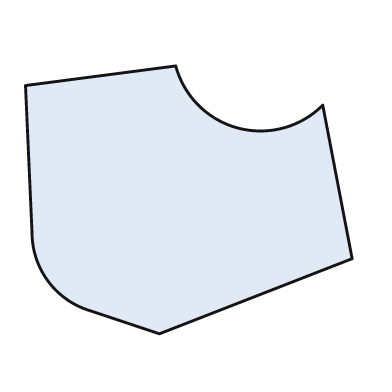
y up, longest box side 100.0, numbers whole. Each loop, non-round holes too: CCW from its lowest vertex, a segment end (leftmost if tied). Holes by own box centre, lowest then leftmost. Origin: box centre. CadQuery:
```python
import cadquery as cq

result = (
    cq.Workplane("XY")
    .moveTo(-9.0, -41.0)
    .lineTo(50.0, -18.0)
    .lineTo(41.0, 29.0)
    .threePointArc((15.0, 22.0), (-4.0, 41.0))
    .lineTo(-50.0, 35.0)
    .lineTo(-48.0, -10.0)
    .threePointArc((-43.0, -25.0), (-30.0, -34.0))
    .close()
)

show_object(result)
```